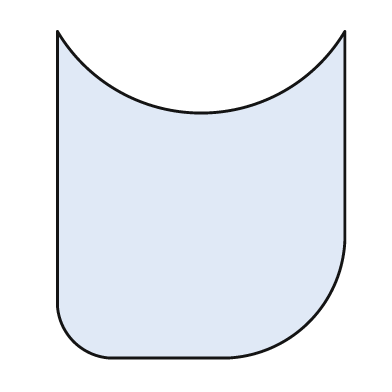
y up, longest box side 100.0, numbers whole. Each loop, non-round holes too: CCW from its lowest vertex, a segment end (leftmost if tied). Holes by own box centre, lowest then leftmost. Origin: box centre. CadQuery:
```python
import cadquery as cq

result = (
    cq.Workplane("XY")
    .moveTo(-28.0, -50.0)
    .lineTo(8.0, -50.0)
    .threePointArc((33.0, -39.0), (44.0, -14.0))
    .lineTo(44.0, 50.0)
    .threePointArc((0.0, 25.0), (-44.0, 50.0))
    .lineTo(-44.0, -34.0)
    .threePointArc((-39.0, -45.0), (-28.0, -50.0))
    .close()
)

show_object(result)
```